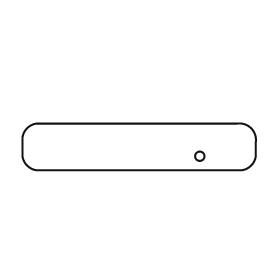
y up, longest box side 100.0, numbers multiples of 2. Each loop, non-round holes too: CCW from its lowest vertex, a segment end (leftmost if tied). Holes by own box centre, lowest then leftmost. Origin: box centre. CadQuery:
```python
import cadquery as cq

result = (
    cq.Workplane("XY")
    .moveTo(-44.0, -10.0)
    .lineTo(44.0, -10.0)
    .threePointArc((48.0, -8.0), (50.0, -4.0))
    .lineTo(50.0, 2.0)
    .threePointArc((48.0, 8.0), (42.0, 10.0))
    .lineTo(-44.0, 10.0)
    .threePointArc((-48.0, 8.0), (-50.0, 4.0))
    .lineTo(-50.0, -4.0)
    .threePointArc((-48.0, -8.0), (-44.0, -10.0))
    .close()
    .moveTo(26.0, -4.0)
    .circle(2.0)
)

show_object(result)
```